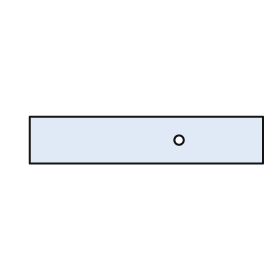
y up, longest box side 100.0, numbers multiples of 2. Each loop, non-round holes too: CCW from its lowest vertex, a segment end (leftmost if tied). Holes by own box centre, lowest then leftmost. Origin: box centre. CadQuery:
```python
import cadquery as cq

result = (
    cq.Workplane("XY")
    .moveTo(-50.0, -10.0)
    .lineTo(50.0, -10.0)
    .lineTo(50.0, 10.0)
    .lineTo(-50.0, 10.0)
    .close()
    .moveTo(14.0, 0.0)
    .circle(2.0)
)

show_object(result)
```